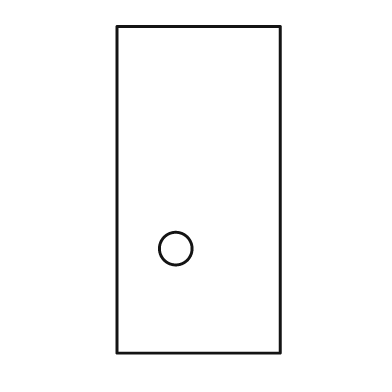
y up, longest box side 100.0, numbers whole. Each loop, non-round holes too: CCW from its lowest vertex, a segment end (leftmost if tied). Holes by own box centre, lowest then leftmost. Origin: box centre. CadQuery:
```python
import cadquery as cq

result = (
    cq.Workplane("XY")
    .moveTo(-25.0, -50.0)
    .lineTo(25.0, -50.0)
    .lineTo(25.0, 50.0)
    .lineTo(-25.0, 50.0)
    .close()
    .moveTo(-7.0, -18.0)
    .circle(5.0)
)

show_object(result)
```